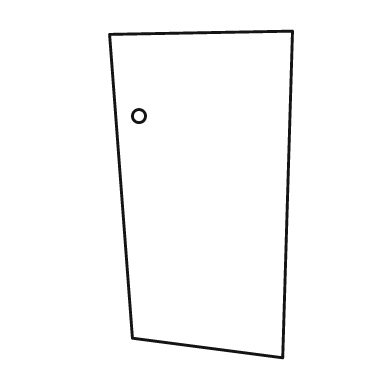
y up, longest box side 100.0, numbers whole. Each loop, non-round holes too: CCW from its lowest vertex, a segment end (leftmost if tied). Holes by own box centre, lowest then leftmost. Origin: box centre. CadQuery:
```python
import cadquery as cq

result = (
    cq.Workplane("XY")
    .moveTo(25.0, -50.0)
    .lineTo(28.0, 50.0)
    .lineTo(-28.0, 49.0)
    .lineTo(-21.0, -44.0)
    .close()
    .moveTo(-19.0, 24.0)
    .circle(2.0)
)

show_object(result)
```